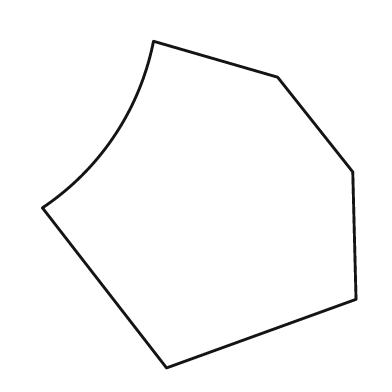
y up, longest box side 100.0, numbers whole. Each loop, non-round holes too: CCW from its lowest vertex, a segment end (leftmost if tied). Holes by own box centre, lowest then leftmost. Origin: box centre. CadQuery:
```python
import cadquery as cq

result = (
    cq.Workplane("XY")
    .moveTo(-10.0, -50.0)
    .lineTo(48.0, -29.0)
    .lineTo(47.0, 10.0)
    .lineTo(24.0, 39.0)
    .lineTo(-14.0, 50.0)
    .threePointArc((-26.0, 21.0), (-48.0, -1.0))
    .close()
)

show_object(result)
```